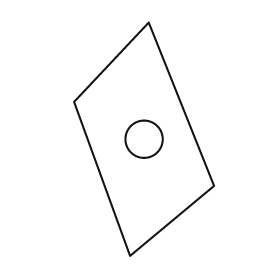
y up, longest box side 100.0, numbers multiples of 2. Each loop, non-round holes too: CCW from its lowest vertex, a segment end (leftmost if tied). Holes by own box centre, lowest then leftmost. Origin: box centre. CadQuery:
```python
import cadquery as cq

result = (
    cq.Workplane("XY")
    .moveTo(-6.0, -50.0)
    .lineTo(30.0, -20.0)
    .lineTo(2.0, 50.0)
    .lineTo(-30.0, 16.0)
    .close()
    .moveTo(0.0, 0.0)
    .circle(8.0)
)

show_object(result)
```